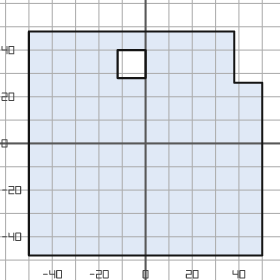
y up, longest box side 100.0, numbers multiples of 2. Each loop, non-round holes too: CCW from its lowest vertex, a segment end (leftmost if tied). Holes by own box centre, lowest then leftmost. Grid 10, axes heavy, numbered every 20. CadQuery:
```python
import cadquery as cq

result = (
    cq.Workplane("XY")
    .moveTo(-50.0, -48.0)
    .lineTo(50.0, -48.0)
    .lineTo(50.0, 26.0)
    .lineTo(38.0, 26.0)
    .lineTo(38.0, 48.0)
    .lineTo(-50.0, 48.0)
    .close()
    .moveTo(-12.0, 28.0)
    .lineTo(0.0, 28.0)
    .lineTo(0.0, 40.0)
    .lineTo(-12.0, 40.0)
    .close()
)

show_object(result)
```